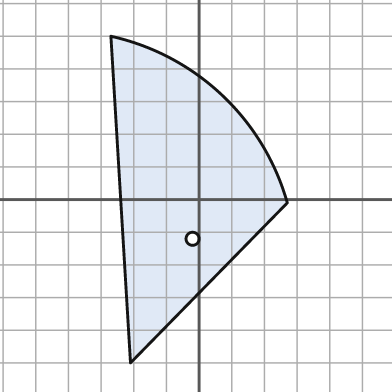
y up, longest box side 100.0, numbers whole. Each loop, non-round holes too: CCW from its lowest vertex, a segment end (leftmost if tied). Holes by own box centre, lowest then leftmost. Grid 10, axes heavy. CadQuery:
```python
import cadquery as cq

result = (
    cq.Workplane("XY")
    .moveTo(-21.0, -50.0)
    .lineTo(27.0, -1.0)
    .threePointArc((7.0, 32.0), (-27.0, 50.0))
    .close()
    .moveTo(-2.0, -12.0)
    .circle(2.0)
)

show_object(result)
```